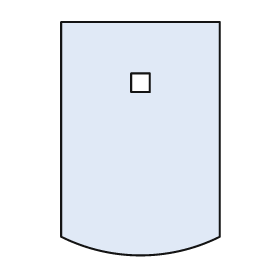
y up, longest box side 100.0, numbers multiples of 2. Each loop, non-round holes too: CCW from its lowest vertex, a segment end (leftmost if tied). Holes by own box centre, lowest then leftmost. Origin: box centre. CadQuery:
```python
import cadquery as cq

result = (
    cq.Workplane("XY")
    .moveTo(-34.0, -42.0)
    .threePointArc((0.0, -50.0), (34.0, -42.0))
    .lineTo(34.0, 50.0)
    .lineTo(-34.0, 50.0)
    .close()
    .moveTo(-4.0, 20.0)
    .lineTo(4.0, 20.0)
    .lineTo(4.0, 28.0)
    .lineTo(-4.0, 28.0)
    .close()
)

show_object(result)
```